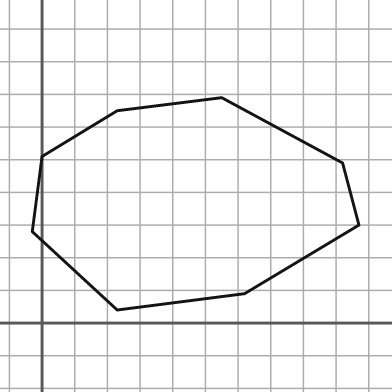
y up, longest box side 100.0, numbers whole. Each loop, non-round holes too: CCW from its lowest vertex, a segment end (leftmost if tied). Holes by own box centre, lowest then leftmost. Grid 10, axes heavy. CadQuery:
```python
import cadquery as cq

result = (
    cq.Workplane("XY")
    .moveTo(23.0, 4.0)
    .lineTo(62.0, 9.0)
    .lineTo(97.0, 30.0)
    .lineTo(92.0, 49.0)
    .lineTo(55.0, 69.0)
    .lineTo(23.0, 65.0)
    .lineTo(0.0, 51.0)
    .lineTo(-3.0, 28.0)
    .close()
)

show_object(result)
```